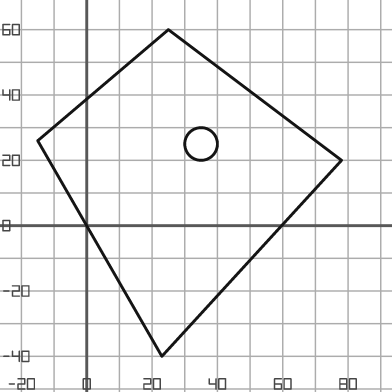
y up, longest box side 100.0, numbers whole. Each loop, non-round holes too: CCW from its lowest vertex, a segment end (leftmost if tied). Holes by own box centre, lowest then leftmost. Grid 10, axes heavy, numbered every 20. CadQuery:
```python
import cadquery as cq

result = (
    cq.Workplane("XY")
    .moveTo(23.0, -40.0)
    .lineTo(78.0, 20.0)
    .lineTo(25.0, 60.0)
    .lineTo(-15.0, 26.0)
    .close()
    .moveTo(35.0, 25.0)
    .circle(5.0)
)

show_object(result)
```